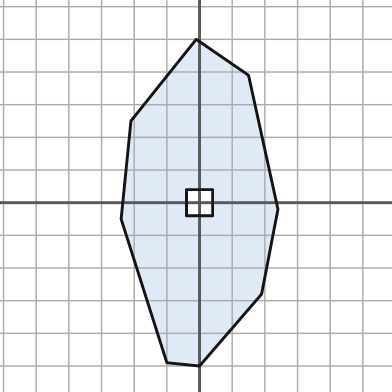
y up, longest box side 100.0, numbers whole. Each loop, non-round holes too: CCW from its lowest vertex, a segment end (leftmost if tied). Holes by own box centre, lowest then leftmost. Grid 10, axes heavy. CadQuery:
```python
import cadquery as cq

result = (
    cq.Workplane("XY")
    .moveTo(0.0, -50.0)
    .lineTo(19.0, -28.0)
    .lineTo(24.0, -2.0)
    .lineTo(15.0, 39.0)
    .lineTo(-1.0, 50.0)
    .lineTo(-21.0, 25.0)
    .lineTo(-24.0, -5.0)
    .lineTo(-10.0, -49.0)
    .close()
    .moveTo(-4.0, -4.0)
    .lineTo(4.0, -4.0)
    .lineTo(4.0, 4.0)
    .lineTo(-4.0, 4.0)
    .close()
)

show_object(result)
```